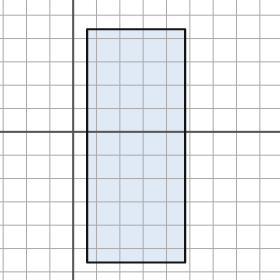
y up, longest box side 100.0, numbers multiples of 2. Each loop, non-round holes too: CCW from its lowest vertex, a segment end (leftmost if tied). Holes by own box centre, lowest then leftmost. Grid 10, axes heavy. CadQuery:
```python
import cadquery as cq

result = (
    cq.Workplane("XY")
    .moveTo(6.0, -56.0)
    .lineTo(48.0, -56.0)
    .lineTo(48.0, 44.0)
    .lineTo(6.0, 44.0)
    .close()
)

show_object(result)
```